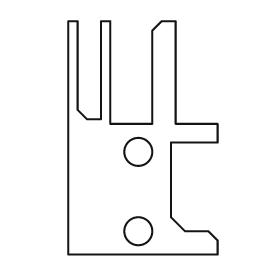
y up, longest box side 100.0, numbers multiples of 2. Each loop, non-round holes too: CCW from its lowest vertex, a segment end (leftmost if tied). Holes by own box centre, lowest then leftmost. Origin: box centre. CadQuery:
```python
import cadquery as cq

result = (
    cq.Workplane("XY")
    .moveTo(-32.0, -50.0)
    .lineTo(32.0, -50.0)
    .lineTo(32.0, -44.0)
    .lineTo(28.0, -40.0)
    .lineTo(18.0, -40.0)
    .lineTo(12.0, -34.0)
    .lineTo(12.0, -2.0)
    .lineTo(32.0, -2.0)
    .lineTo(32.0, 6.0)
    .lineTo(14.0, 6.0)
    .lineTo(14.0, 50.0)
    .lineTo(8.0, 50.0)
    .lineTo(4.0, 46.0)
    .lineTo(4.0, 6.0)
    .lineTo(-14.0, 6.0)
    .lineTo(-14.0, 50.0)
    .lineTo(-18.0, 50.0)
    .lineTo(-18.0, 8.0)
    .lineTo(-24.0, 8.0)
    .lineTo(-28.0, 12.0)
    .lineTo(-28.0, 50.0)
    .lineTo(-32.0, 50.0)
    .close()
    .moveTo(-2.0, -40.0)
    .circle(6.0)
    .moveTo(-2.0, -6.0)
    .circle(6.0)
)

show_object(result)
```